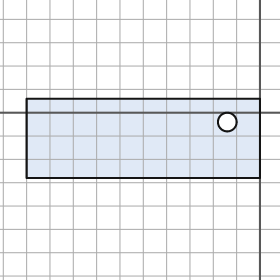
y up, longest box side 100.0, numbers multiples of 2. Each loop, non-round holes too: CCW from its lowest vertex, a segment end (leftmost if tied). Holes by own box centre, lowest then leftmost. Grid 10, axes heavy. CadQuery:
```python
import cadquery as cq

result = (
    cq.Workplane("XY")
    .moveTo(-100.0, -28.0)
    .lineTo(0.0, -28.0)
    .lineTo(0.0, 6.0)
    .lineTo(-100.0, 6.0)
    .close()
    .moveTo(-14.0, -4.0)
    .circle(4.0)
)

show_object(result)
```